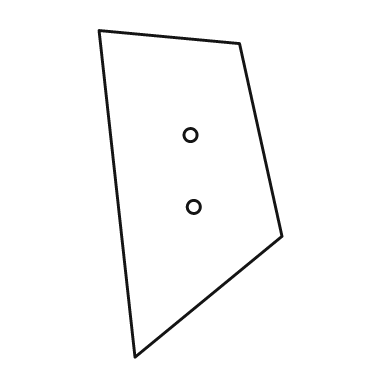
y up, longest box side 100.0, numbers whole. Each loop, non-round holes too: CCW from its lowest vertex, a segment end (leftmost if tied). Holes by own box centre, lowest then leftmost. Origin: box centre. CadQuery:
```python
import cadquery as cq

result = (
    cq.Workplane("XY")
    .moveTo(-17.0, -50.0)
    .lineTo(28.0, -13.0)
    .lineTo(15.0, 46.0)
    .lineTo(-28.0, 50.0)
    .close()
    .moveTo(1.0, -4.0)
    .circle(2.0)
    .moveTo(0.0, 18.0)
    .circle(2.0)
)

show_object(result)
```